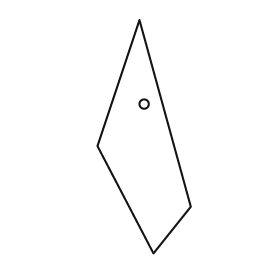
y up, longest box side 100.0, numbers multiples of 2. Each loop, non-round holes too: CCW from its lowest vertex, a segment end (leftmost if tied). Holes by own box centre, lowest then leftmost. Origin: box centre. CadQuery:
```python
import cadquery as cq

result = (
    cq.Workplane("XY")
    .moveTo(4.0, -50.0)
    .lineTo(20.0, -30.0)
    .lineTo(-2.0, 50.0)
    .lineTo(-20.0, -4.0)
    .close()
    .moveTo(0.0, 14.0)
    .circle(2.0)
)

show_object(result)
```